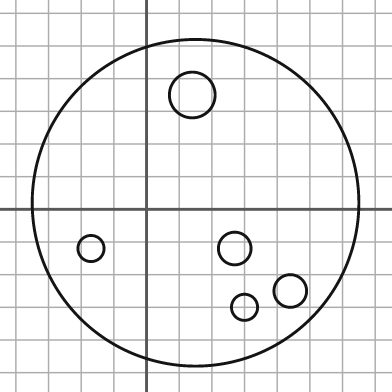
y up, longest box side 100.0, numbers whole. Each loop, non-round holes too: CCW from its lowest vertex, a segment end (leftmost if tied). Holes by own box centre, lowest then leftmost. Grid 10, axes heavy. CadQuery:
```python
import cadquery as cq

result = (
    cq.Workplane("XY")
    .moveTo(15.0, 2.0)
    .circle(50.0)
    .moveTo(30.0, -30.0)
    .circle(4.0)
    .moveTo(44.0, -25.0)
    .circle(5.0)
    .moveTo(-17.0, -12.0)
    .circle(4.0)
    .moveTo(27.0, -12.0)
    .circle(5.0)
    .moveTo(14.0, 35.0)
    .circle(7.0)
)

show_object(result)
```